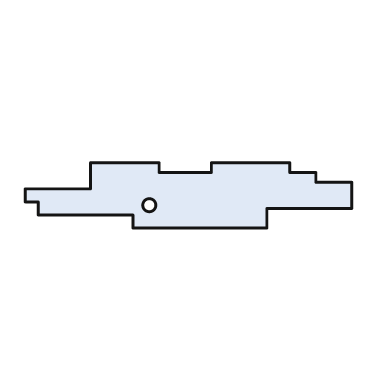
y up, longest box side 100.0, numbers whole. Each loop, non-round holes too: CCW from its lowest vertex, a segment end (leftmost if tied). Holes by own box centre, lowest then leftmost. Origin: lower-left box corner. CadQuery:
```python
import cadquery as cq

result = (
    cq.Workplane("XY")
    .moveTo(33.0, 0.0)
    .lineTo(74.0, 0.0)
    .lineTo(74.0, 6.0)
    .lineTo(100.0, 6.0)
    .lineTo(100.0, 14.0)
    .lineTo(89.0, 14.0)
    .lineTo(89.0, 17.0)
    .lineTo(81.0, 17.0)
    .lineTo(81.0, 20.0)
    .lineTo(57.0, 20.0)
    .lineTo(57.0, 17.0)
    .lineTo(41.0, 17.0)
    .lineTo(41.0, 20.0)
    .lineTo(20.0, 20.0)
    .lineTo(20.0, 12.0)
    .lineTo(0.0, 12.0)
    .lineTo(0.0, 8.0)
    .lineTo(4.0, 8.0)
    .lineTo(4.0, 4.0)
    .lineTo(33.0, 4.0)
    .close()
    .moveTo(38.0, 7.0)
    .circle(2.0)
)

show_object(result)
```